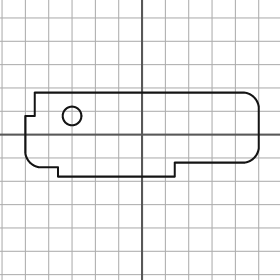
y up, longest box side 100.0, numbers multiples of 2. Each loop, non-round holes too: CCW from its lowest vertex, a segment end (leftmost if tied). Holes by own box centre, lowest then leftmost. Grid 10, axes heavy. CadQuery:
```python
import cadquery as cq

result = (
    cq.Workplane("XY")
    .moveTo(-36.0, -18.0)
    .lineTo(14.0, -18.0)
    .lineTo(14.0, -12.0)
    .lineTo(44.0, -12.0)
    .threePointArc((48.0, -10.0), (50.0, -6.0))
    .lineTo(50.0, 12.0)
    .threePointArc((48.0, 16.0), (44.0, 18.0))
    .lineTo(-46.0, 18.0)
    .lineTo(-46.0, 8.0)
    .lineTo(-50.0, 8.0)
    .lineTo(-50.0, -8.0)
    .threePointArc((-48.0, -12.0), (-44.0, -14.0))
    .lineTo(-36.0, -14.0)
    .close()
    .moveTo(-30.0, 8.0)
    .circle(4.0)
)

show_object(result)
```